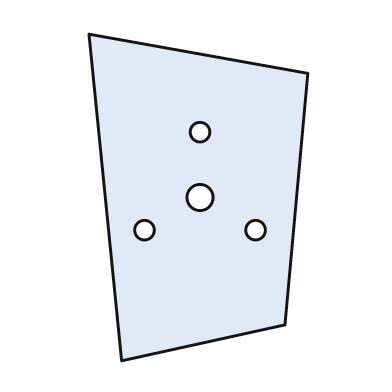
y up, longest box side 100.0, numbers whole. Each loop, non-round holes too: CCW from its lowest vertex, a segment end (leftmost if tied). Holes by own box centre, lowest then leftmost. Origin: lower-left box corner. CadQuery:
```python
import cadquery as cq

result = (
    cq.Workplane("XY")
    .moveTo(10.0, 0.0)
    .lineTo(60.0, 11.0)
    .lineTo(67.0, 88.0)
    .lineTo(0.0, 100.0)
    .close()
    .moveTo(17.0, 40.0)
    .circle(3.0)
    .moveTo(51.0, 40.0)
    .circle(3.0)
    .moveTo(34.0, 50.0)
    .circle(4.0)
    .moveTo(34.0, 70.0)
    .circle(3.0)
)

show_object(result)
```